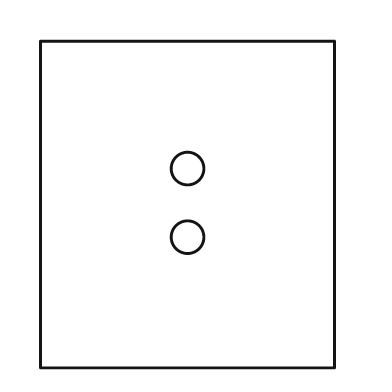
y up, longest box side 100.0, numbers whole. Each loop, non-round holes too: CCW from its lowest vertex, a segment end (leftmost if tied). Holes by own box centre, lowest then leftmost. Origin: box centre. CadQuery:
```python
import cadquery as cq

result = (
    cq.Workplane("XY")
    .moveTo(-45.0, -50.0)
    .lineTo(45.0, -50.0)
    .lineTo(45.0, 50.0)
    .lineTo(-45.0, 50.0)
    .close()
    .moveTo(0.0, -10.0)
    .circle(5.0)
    .moveTo(0.0, 11.0)
    .circle(5.0)
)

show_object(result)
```